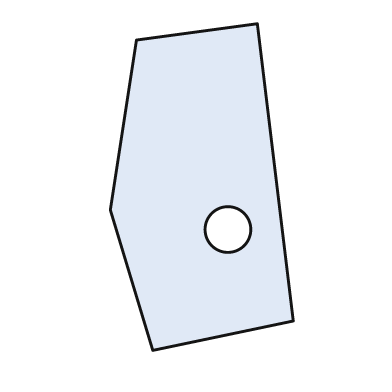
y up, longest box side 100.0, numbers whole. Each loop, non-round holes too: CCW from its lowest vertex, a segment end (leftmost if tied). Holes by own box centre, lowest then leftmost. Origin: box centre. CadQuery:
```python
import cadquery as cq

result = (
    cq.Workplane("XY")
    .moveTo(-15.0, -50.0)
    .lineTo(28.0, -41.0)
    .lineTo(17.0, 50.0)
    .lineTo(-20.0, 45.0)
    .lineTo(-28.0, -7.0)
    .close()
    .moveTo(8.0, -13.0)
    .circle(7.0)
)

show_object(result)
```